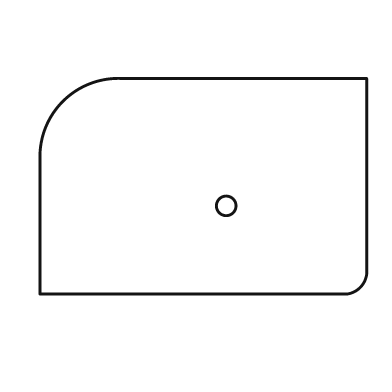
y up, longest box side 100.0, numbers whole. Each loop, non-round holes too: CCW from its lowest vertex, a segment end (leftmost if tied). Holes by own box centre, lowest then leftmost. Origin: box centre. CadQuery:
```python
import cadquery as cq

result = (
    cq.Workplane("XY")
    .moveTo(-50.0, -33.0)
    .lineTo(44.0, -33.0)
    .threePointArc((48.0, -31.0), (50.0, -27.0))
    .lineTo(50.0, 33.0)
    .lineTo(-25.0, 33.0)
    .threePointArc((-43.0, 26.0), (-50.0, 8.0))
    .close()
    .moveTo(7.0, -6.0)
    .circle(3.0)
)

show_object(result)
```